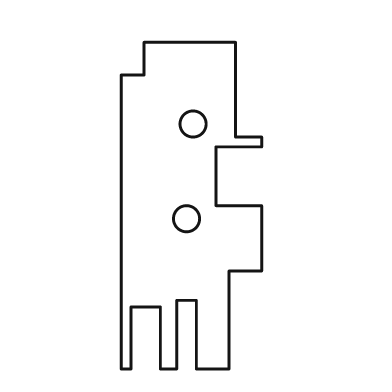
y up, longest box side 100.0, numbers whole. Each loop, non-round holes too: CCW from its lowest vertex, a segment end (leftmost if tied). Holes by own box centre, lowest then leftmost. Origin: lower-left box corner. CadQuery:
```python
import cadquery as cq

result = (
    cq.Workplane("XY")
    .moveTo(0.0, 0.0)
    .lineTo(3.0, 0.0)
    .lineTo(3.0, 19.0)
    .lineTo(12.0, 19.0)
    .lineTo(12.0, 0.0)
    .lineTo(17.0, 0.0)
    .lineTo(17.0, 21.0)
    .lineTo(23.0, 21.0)
    .lineTo(23.0, 0.0)
    .lineTo(33.0, 0.0)
    .lineTo(33.0, 30.0)
    .lineTo(43.0, 30.0)
    .lineTo(43.0, 50.0)
    .lineTo(29.0, 50.0)
    .lineTo(29.0, 68.0)
    .lineTo(43.0, 68.0)
    .lineTo(43.0, 71.0)
    .lineTo(35.0, 71.0)
    .lineTo(35.0, 100.0)
    .lineTo(7.0, 100.0)
    .lineTo(7.0, 90.0)
    .lineTo(0.0, 90.0)
    .close()
    .moveTo(20.0, 46.0)
    .circle(4.0)
    .moveTo(22.0, 75.0)
    .circle(4.0)
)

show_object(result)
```